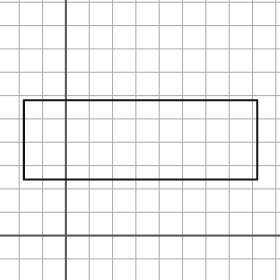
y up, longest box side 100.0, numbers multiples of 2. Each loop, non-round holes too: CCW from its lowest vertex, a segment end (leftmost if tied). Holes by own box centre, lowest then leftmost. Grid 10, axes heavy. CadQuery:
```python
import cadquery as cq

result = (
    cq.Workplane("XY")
    .moveTo(-18.0, 24.0)
    .lineTo(82.0, 24.0)
    .lineTo(82.0, 58.0)
    .lineTo(-18.0, 58.0)
    .close()
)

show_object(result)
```